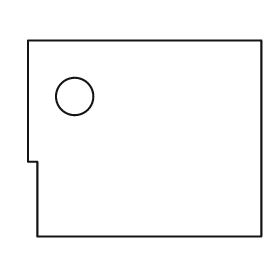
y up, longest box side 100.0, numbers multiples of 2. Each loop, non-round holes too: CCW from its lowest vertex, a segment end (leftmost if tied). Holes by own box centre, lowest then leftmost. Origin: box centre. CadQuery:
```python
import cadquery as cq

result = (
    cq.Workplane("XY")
    .moveTo(-46.0, -42.0)
    .lineTo(50.0, -42.0)
    .lineTo(50.0, 42.0)
    .lineTo(-50.0, 42.0)
    .lineTo(-50.0, -10.0)
    .lineTo(-46.0, -10.0)
    .close()
    .moveTo(-30.0, 18.0)
    .circle(8.0)
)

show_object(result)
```